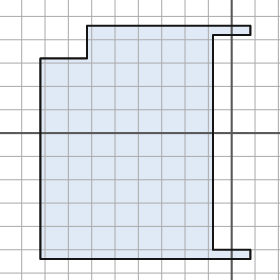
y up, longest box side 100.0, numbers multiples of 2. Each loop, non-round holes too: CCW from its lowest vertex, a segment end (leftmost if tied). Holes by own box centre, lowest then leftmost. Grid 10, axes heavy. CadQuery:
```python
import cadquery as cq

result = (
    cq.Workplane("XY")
    .moveTo(-82.0, -54.0)
    .lineTo(8.0, -54.0)
    .lineTo(8.0, -50.0)
    .lineTo(-8.0, -50.0)
    .lineTo(-8.0, 42.0)
    .lineTo(8.0, 42.0)
    .lineTo(8.0, 46.0)
    .lineTo(-62.0, 46.0)
    .lineTo(-62.0, 32.0)
    .lineTo(-82.0, 32.0)
    .close()
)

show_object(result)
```